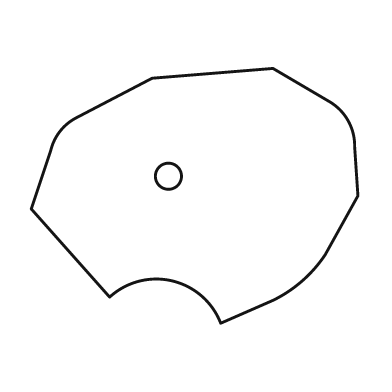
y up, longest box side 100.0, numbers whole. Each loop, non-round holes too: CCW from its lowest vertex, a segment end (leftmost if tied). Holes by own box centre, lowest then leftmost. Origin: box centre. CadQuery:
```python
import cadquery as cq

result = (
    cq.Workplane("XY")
    .moveTo(8.0, -39.0)
    .lineTo(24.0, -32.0)
    .threePointArc((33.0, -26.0), (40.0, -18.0))
    .lineTo(50.0, 0.0)
    .lineTo(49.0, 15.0)
    .threePointArc((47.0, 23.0), (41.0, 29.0))
    .lineTo(24.0, 39.0)
    .lineTo(-13.0, 36.0)
    .lineTo(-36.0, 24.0)
    .threePointArc((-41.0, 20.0), (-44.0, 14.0))
    .lineTo(-50.0, -4.0)
    .lineTo(-26.0, -31.0)
    .threePointArc((-7.0, -26.0), (8.0, -39.0))
    .close()
    .moveTo(-8.0, 6.0)
    .circle(4.0)
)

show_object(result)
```